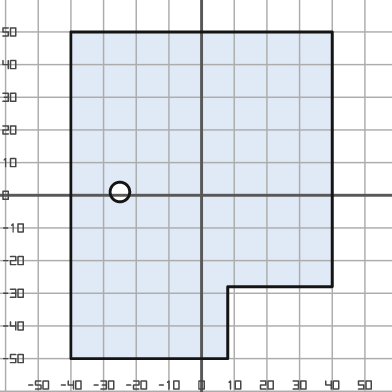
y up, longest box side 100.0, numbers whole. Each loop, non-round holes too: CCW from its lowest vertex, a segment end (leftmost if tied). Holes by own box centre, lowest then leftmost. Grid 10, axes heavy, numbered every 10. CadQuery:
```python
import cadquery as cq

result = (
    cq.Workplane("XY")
    .moveTo(-40.0, -50.0)
    .lineTo(8.0, -50.0)
    .lineTo(8.0, -28.0)
    .lineTo(40.0, -28.0)
    .lineTo(40.0, 50.0)
    .lineTo(-40.0, 50.0)
    .close()
    .moveTo(-25.0, 1.0)
    .circle(3.0)
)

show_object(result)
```